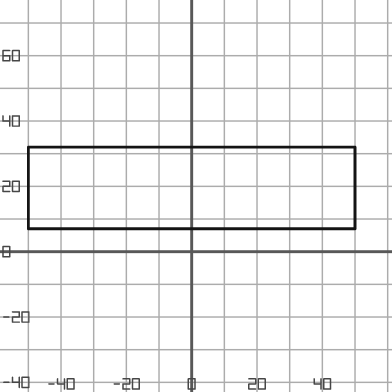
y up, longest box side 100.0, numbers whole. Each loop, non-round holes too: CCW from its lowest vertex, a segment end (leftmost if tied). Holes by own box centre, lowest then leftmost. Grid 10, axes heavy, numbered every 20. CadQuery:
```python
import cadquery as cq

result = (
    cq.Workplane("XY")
    .moveTo(-50.0, 7.0)
    .lineTo(50.0, 7.0)
    .lineTo(50.0, 32.0)
    .lineTo(-50.0, 32.0)
    .close()
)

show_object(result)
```